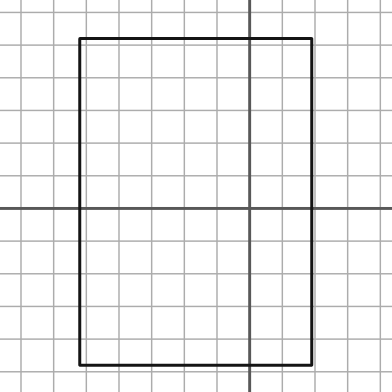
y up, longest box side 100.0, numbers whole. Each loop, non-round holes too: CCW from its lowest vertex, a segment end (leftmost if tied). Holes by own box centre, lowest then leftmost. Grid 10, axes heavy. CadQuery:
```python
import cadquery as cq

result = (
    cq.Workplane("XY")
    .moveTo(-52.0, -48.0)
    .lineTo(19.0, -48.0)
    .lineTo(19.0, 52.0)
    .lineTo(-52.0, 52.0)
    .close()
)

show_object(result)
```